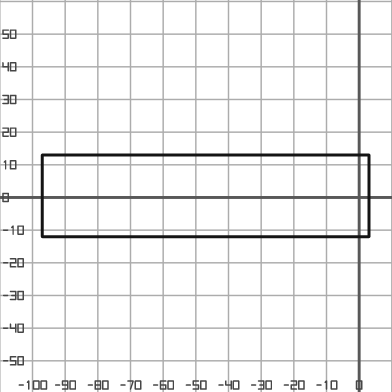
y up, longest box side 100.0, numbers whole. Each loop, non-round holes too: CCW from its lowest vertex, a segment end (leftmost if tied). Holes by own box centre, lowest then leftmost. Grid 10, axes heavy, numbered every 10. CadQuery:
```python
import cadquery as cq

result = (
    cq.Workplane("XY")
    .moveTo(-97.0, -12.0)
    .lineTo(3.0, -12.0)
    .lineTo(3.0, 13.0)
    .lineTo(-97.0, 13.0)
    .close()
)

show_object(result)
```